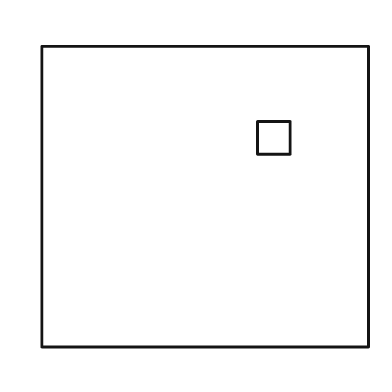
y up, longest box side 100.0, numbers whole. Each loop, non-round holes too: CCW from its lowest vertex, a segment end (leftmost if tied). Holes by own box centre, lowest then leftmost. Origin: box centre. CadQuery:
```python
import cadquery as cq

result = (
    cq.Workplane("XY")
    .moveTo(-50.0, -46.0)
    .lineTo(50.0, -46.0)
    .lineTo(50.0, 46.0)
    .lineTo(-50.0, 46.0)
    .close()
    .moveTo(16.0, 13.0)
    .lineTo(26.0, 13.0)
    .lineTo(26.0, 23.0)
    .lineTo(16.0, 23.0)
    .close()
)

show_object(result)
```